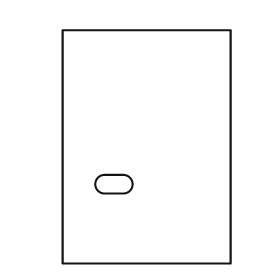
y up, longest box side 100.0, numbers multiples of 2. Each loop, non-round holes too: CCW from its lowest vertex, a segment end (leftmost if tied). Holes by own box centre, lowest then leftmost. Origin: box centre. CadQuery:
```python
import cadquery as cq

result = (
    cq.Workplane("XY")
    .moveTo(-36.0, -50.0)
    .lineTo(36.0, -50.0)
    .lineTo(36.0, 50.0)
    .lineTo(-36.0, 50.0)
    .close()
    .moveTo(-18.0, -20.0)
    .lineTo(-10.0, -20.0)
    .threePointArc((-6.0, -16.0), (-10.0, -12.0))
    .lineTo(-18.0, -12.0)
    .threePointArc((-22.0, -16.0), (-18.0, -20.0))
    .close()
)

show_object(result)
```